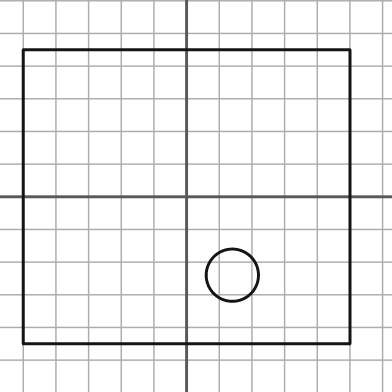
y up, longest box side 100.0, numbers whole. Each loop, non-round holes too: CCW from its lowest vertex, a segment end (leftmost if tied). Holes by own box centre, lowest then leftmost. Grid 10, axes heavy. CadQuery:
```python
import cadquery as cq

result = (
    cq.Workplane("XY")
    .moveTo(-50.0, -45.0)
    .lineTo(50.0, -45.0)
    .lineTo(50.0, 45.0)
    .lineTo(-50.0, 45.0)
    .close()
    .moveTo(14.0, -24.0)
    .circle(8.0)
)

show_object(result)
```